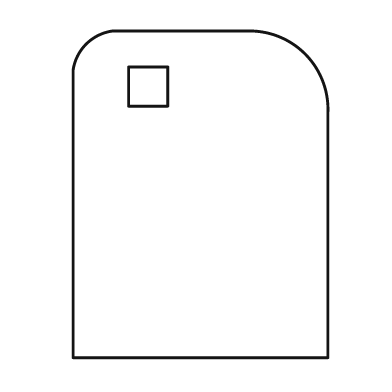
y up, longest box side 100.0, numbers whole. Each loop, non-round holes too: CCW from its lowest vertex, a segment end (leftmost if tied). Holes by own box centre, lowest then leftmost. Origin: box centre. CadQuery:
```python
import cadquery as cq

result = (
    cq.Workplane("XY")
    .moveTo(-39.0, -50.0)
    .lineTo(39.0, -50.0)
    .lineTo(39.0, 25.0)
    .threePointArc((32.0, 43.0), (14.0, 50.0))
    .lineTo(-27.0, 50.0)
    .threePointArc((-35.0, 46.0), (-39.0, 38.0))
    .close()
    .moveTo(-22.0, 27.0)
    .lineTo(-10.0, 27.0)
    .lineTo(-10.0, 39.0)
    .lineTo(-22.0, 39.0)
    .close()
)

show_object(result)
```